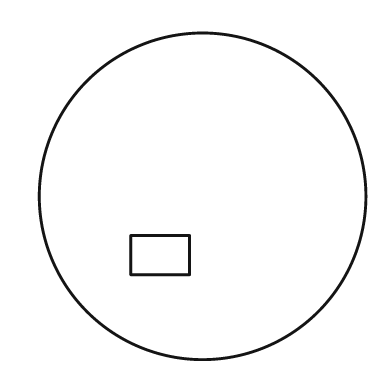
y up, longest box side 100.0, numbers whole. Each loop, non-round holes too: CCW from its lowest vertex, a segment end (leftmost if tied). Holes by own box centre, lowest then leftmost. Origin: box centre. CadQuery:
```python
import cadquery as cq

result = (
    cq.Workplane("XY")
    .moveTo(0.0, 0.0)
    .circle(50.0)
    .moveTo(-22.0, -24.0)
    .lineTo(-4.0, -24.0)
    .lineTo(-4.0, -12.0)
    .lineTo(-22.0, -12.0)
    .close()
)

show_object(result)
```